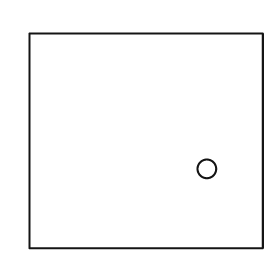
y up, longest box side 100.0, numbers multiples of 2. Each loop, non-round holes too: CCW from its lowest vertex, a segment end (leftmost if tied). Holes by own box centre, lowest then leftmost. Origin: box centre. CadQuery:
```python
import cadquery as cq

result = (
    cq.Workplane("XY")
    .moveTo(-50.0, -46.0)
    .lineTo(50.0, -46.0)
    .lineTo(50.0, 46.0)
    .lineTo(-50.0, 46.0)
    .close()
    .moveTo(26.0, -12.0)
    .circle(4.0)
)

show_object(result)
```